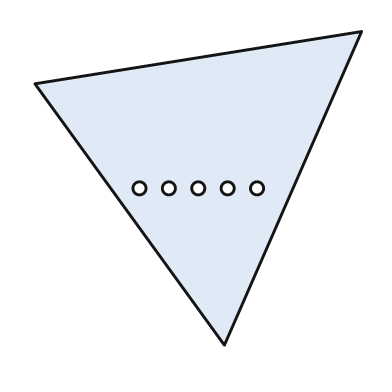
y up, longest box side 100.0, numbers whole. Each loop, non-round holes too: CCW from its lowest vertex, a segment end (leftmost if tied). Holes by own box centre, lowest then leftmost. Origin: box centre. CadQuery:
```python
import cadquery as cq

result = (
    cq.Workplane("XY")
    .moveTo(8.0, -48.0)
    .lineTo(50.0, 48.0)
    .lineTo(-50.0, 32.0)
    .close()
    .moveTo(-18.0, 0.0)
    .circle(2.0)
    .moveTo(-9.0, 0.0)
    .circle(2.0)
    .moveTo(0.0, 0.0)
    .circle(2.0)
    .moveTo(9.0, 0.0)
    .circle(2.0)
    .moveTo(18.0, 0.0)
    .circle(2.0)
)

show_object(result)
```